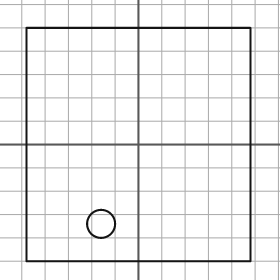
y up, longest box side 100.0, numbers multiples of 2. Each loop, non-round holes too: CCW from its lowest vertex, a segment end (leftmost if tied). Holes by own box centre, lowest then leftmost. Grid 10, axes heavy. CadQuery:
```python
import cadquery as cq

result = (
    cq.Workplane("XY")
    .moveTo(-48.0, -50.0)
    .lineTo(48.0, -50.0)
    .lineTo(48.0, 50.0)
    .lineTo(-48.0, 50.0)
    .close()
    .moveTo(-16.0, -34.0)
    .circle(6.0)
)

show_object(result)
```